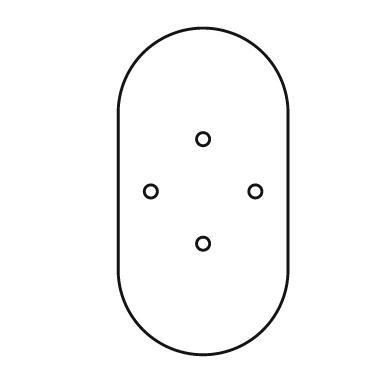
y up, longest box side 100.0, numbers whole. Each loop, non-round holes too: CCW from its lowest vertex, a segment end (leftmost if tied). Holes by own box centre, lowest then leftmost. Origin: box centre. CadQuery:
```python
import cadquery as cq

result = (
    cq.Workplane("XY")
    .moveTo(-26.0, -24.0)
    .threePointArc((0.0, -50.0), (26.0, -24.0))
    .lineTo(26.0, 24.0)
    .threePointArc((0.0, 50.0), (-26.0, 24.0))
    .close()
    .moveTo(0.0, -16.0)
    .circle(2.0)
    .moveTo(-16.0, 0.0)
    .circle(2.0)
    .moveTo(16.0, 0.0)
    .circle(2.0)
    .moveTo(0.0, 16.0)
    .circle(2.0)
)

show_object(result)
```